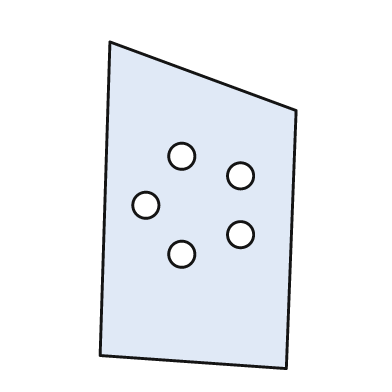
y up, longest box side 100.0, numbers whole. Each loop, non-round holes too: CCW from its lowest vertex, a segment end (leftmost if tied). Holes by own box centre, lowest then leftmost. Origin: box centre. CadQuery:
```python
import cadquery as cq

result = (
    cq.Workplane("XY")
    .moveTo(27.0, -50.0)
    .lineTo(30.0, 29.0)
    .lineTo(-27.0, 50.0)
    .lineTo(-30.0, -46.0)
    .close()
    .moveTo(-5.0, -15.0)
    .circle(4.0)
    .moveTo(13.0, -9.0)
    .circle(4.0)
    .moveTo(-16.0, 0.0)
    .circle(4.0)
    .moveTo(13.0, 9.0)
    .circle(4.0)
    .moveTo(-5.0, 15.0)
    .circle(4.0)
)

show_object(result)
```